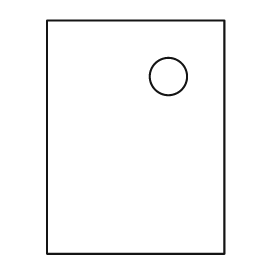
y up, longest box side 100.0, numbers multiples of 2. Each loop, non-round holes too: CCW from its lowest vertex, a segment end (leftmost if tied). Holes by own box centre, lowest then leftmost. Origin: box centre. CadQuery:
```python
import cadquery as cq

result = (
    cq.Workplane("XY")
    .moveTo(-38.0, -50.0)
    .lineTo(38.0, -50.0)
    .lineTo(38.0, 50.0)
    .lineTo(-38.0, 50.0)
    .close()
    .moveTo(14.0, 26.0)
    .circle(8.0)
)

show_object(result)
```